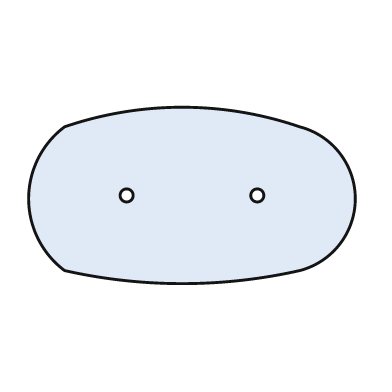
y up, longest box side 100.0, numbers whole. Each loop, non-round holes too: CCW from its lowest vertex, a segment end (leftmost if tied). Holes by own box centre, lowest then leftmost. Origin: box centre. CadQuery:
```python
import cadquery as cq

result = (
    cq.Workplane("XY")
    .moveTo(-39.0, -23.0)
    .threePointArc((-3.0, -27.0), (33.0, -23.0))
    .threePointArc((50.0, -1.0), (33.0, 21.0))
    .threePointArc((-3.0, 27.0), (-39.0, 21.0))
    .threePointArc((-50.0, -1.0), (-39.0, -23.0))
    .close()
    .moveTo(-20.0, 0.0)
    .circle(2.0)
    .moveTo(20.0, 0.0)
    .circle(2.0)
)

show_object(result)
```